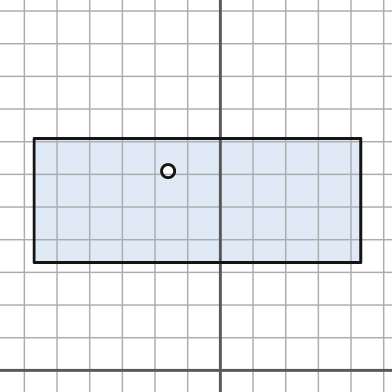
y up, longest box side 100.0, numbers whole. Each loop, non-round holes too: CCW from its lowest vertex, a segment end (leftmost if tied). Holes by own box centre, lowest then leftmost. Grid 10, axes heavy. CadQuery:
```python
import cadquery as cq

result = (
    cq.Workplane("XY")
    .moveTo(-57.0, 33.0)
    .lineTo(43.0, 33.0)
    .lineTo(43.0, 71.0)
    .lineTo(-57.0, 71.0)
    .close()
    .moveTo(-16.0, 61.0)
    .circle(2.0)
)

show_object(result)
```